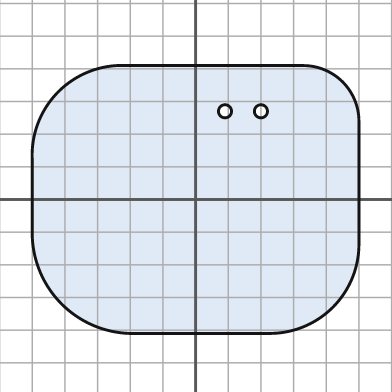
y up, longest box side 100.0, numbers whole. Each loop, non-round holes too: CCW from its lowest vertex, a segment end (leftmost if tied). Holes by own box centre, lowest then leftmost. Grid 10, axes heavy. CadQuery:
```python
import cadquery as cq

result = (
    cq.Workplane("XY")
    .moveTo(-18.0, -41.0)
    .lineTo(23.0, -41.0)
    .threePointArc((42.0, -33.0), (50.0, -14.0))
    .lineTo(50.0, 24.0)
    .threePointArc((45.0, 36.0), (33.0, 41.0))
    .lineTo(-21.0, 41.0)
    .threePointArc((-42.0, 33.0), (-50.0, 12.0))
    .lineTo(-50.0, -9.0)
    .threePointArc((-41.0, -32.0), (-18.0, -41.0))
    .close()
    .moveTo(9.0, 27.0)
    .circle(2.0)
    .moveTo(20.0, 27.0)
    .circle(2.0)
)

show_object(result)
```